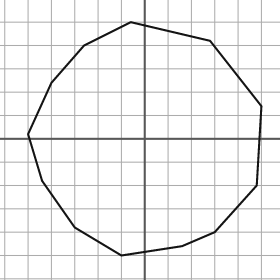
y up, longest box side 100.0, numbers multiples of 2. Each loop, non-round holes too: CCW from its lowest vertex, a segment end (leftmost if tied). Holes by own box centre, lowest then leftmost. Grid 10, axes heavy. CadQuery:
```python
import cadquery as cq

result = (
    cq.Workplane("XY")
    .moveTo(-10.0, -50.0)
    .lineTo(16.0, -46.0)
    .lineTo(30.0, -40.0)
    .lineTo(48.0, -20.0)
    .lineTo(50.0, 14.0)
    .lineTo(28.0, 42.0)
    .lineTo(-6.0, 50.0)
    .lineTo(-26.0, 40.0)
    .lineTo(-40.0, 24.0)
    .lineTo(-50.0, 2.0)
    .lineTo(-44.0, -18.0)
    .lineTo(-30.0, -38.0)
    .close()
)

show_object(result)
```